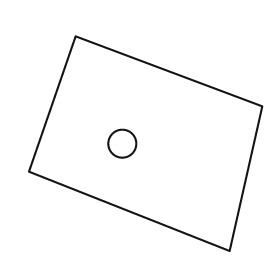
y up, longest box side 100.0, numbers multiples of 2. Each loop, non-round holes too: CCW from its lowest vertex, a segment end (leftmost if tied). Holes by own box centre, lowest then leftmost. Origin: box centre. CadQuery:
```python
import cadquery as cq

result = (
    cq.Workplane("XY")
    .moveTo(36.0, -46.0)
    .lineTo(50.0, 16.0)
    .lineTo(-30.0, 46.0)
    .lineTo(-50.0, -12.0)
    .close()
    .moveTo(-10.0, 0.0)
    .circle(6.0)
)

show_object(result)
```